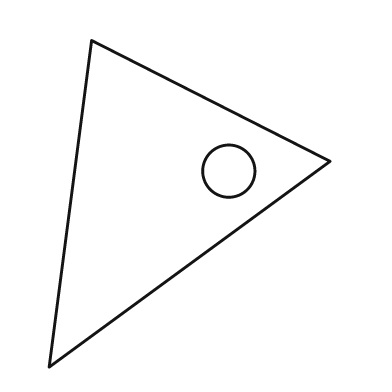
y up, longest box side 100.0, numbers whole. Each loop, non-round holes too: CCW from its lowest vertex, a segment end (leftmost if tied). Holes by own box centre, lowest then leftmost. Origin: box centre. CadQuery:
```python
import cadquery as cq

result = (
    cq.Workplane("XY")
    .moveTo(-43.0, -50.0)
    .lineTo(43.0, 13.0)
    .lineTo(-30.0, 50.0)
    .close()
    .moveTo(12.0, 10.0)
    .circle(8.0)
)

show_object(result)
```